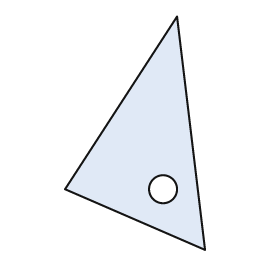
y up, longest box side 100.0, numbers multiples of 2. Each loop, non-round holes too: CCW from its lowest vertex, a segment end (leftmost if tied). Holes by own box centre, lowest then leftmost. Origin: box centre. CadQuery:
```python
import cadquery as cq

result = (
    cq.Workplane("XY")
    .moveTo(30.0, -50.0)
    .lineTo(18.0, 50.0)
    .lineTo(-30.0, -24.0)
    .close()
    .moveTo(12.0, -24.0)
    .circle(6.0)
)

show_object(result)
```